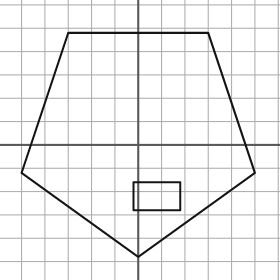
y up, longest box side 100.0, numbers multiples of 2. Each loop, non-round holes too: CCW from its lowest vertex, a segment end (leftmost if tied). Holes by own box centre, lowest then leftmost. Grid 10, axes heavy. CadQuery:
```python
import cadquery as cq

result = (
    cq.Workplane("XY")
    .moveTo(0.0, -48.0)
    .lineTo(50.0, -12.0)
    .lineTo(30.0, 48.0)
    .lineTo(-30.0, 48.0)
    .lineTo(-50.0, -12.0)
    .close()
    .moveTo(-2.0, -28.0)
    .lineTo(18.0, -28.0)
    .lineTo(18.0, -16.0)
    .lineTo(-2.0, -16.0)
    .close()
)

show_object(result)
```